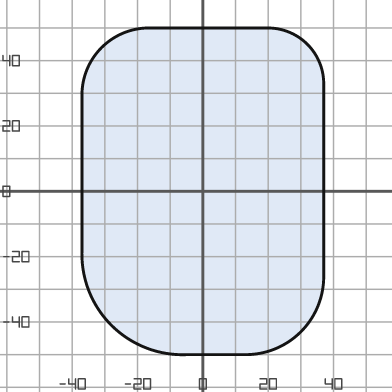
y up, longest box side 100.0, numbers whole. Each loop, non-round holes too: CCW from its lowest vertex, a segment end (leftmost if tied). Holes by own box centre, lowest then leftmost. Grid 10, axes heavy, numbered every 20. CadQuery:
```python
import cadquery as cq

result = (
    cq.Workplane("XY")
    .moveTo(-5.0, -50.0)
    .lineTo(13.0, -50.0)
    .threePointArc((30.0, -43.0), (37.0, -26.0))
    .lineTo(37.0, 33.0)
    .threePointArc((32.0, 45.0), (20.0, 50.0))
    .lineTo(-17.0, 50.0)
    .threePointArc((-31.0, 44.0), (-37.0, 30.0))
    .lineTo(-37.0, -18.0)
    .threePointArc((-28.0, -41.0), (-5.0, -50.0))
    .close()
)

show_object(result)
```